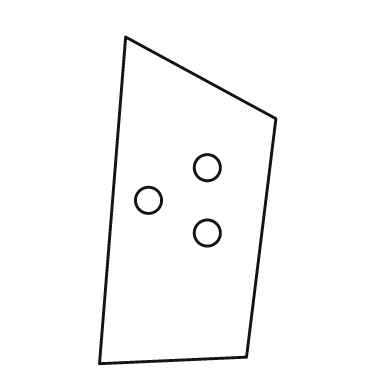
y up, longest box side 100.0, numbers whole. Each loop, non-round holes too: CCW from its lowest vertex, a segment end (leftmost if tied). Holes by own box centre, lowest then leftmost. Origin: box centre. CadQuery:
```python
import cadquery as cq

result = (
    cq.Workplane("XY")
    .moveTo(-27.0, -50.0)
    .lineTo(18.0, -48.0)
    .lineTo(27.0, 25.0)
    .lineTo(-19.0, 50.0)
    .close()
    .moveTo(6.0, -10.0)
    .circle(4.0)
    .moveTo(-12.0, 0.0)
    .circle(4.0)
    .moveTo(6.0, 10.0)
    .circle(4.0)
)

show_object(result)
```